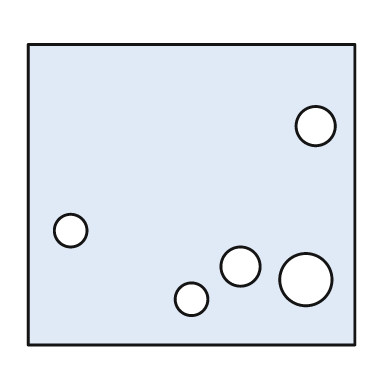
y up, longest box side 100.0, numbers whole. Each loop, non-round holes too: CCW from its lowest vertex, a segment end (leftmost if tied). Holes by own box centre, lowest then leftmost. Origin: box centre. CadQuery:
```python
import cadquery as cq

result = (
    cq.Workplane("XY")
    .moveTo(-50.0, -46.0)
    .lineTo(50.0, -46.0)
    .lineTo(50.0, 46.0)
    .lineTo(-50.0, 46.0)
    .close()
    .moveTo(0.0, -32.0)
    .circle(5.0)
    .moveTo(35.0, -26.0)
    .circle(8.0)
    .moveTo(15.0, -22.0)
    .circle(6.0)
    .moveTo(-37.0, -11.0)
    .circle(5.0)
    .moveTo(38.0, 21.0)
    .circle(6.0)
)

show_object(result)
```